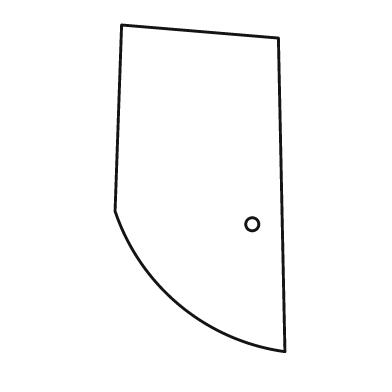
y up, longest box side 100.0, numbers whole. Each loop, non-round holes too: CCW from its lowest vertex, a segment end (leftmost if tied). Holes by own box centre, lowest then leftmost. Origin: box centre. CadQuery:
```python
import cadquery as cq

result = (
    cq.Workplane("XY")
    .moveTo(26.0, -50.0)
    .lineTo(24.0, 46.0)
    .lineTo(-24.0, 50.0)
    .lineTo(-26.0, -7.0)
    .threePointArc((-6.0, -36.0), (26.0, -50.0))
    .close()
    .moveTo(16.0, -11.0)
    .circle(2.0)
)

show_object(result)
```